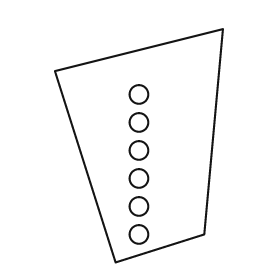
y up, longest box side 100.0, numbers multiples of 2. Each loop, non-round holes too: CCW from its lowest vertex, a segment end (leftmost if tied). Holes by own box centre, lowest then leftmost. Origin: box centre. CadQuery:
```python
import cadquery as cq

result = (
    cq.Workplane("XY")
    .moveTo(-10.0, -50.0)
    .lineTo(28.0, -38.0)
    .lineTo(36.0, 50.0)
    .lineTo(-36.0, 32.0)
    .close()
    .moveTo(0.0, -38.0)
    .circle(4.0)
    .moveTo(0.0, -26.0)
    .circle(4.0)
    .moveTo(0.0, -14.0)
    .circle(4.0)
    .moveTo(0.0, -2.0)
    .circle(4.0)
    .moveTo(0.0, 10.0)
    .circle(4.0)
    .moveTo(0.0, 22.0)
    .circle(4.0)
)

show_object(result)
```